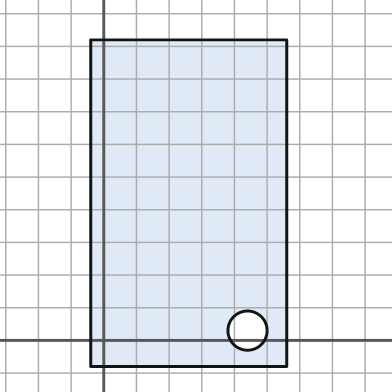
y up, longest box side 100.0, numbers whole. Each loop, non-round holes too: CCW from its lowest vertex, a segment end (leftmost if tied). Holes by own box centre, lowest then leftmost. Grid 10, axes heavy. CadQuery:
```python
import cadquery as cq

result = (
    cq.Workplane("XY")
    .moveTo(-4.0, -8.0)
    .lineTo(56.0, -8.0)
    .lineTo(56.0, 92.0)
    .lineTo(-4.0, 92.0)
    .close()
    .moveTo(44.0, 3.0)
    .circle(6.0)
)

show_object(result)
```